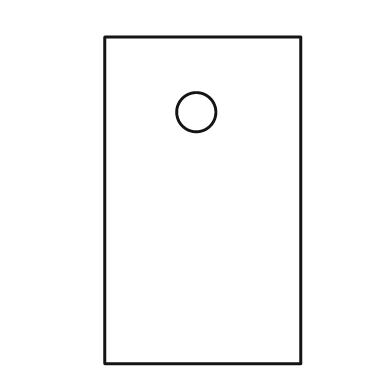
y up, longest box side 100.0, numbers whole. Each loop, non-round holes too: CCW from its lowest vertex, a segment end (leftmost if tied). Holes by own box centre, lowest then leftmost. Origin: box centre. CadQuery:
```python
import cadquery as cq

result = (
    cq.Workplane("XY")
    .moveTo(-30.0, -50.0)
    .lineTo(30.0, -50.0)
    .lineTo(30.0, 50.0)
    .lineTo(-30.0, 50.0)
    .close()
    .moveTo(-2.0, 27.0)
    .circle(6.0)
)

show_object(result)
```